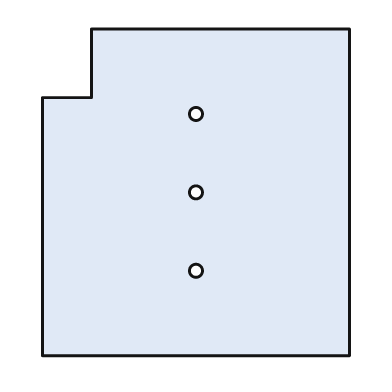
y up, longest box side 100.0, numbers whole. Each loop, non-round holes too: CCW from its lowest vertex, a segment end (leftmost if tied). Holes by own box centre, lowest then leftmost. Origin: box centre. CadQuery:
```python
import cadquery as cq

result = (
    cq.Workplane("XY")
    .moveTo(-47.0, -50.0)
    .lineTo(47.0, -50.0)
    .lineTo(47.0, 50.0)
    .lineTo(-32.0, 50.0)
    .lineTo(-32.0, 29.0)
    .lineTo(-47.0, 29.0)
    .close()
    .moveTo(0.0, -24.0)
    .circle(2.0)
    .moveTo(0.0, 0.0)
    .circle(2.0)
    .moveTo(0.0, 24.0)
    .circle(2.0)
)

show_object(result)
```